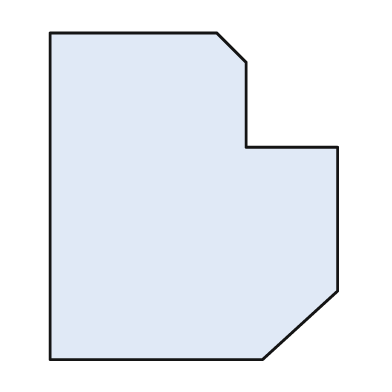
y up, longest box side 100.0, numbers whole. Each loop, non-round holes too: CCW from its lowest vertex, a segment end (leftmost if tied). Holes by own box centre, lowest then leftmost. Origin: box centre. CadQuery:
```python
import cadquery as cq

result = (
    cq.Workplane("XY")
    .moveTo(-44.0, -50.0)
    .lineTo(21.0, -50.0)
    .lineTo(44.0, -29.0)
    .lineTo(44.0, 15.0)
    .lineTo(16.0, 15.0)
    .lineTo(16.0, 41.0)
    .lineTo(7.0, 50.0)
    .lineTo(-44.0, 50.0)
    .close()
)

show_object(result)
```